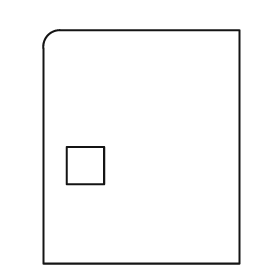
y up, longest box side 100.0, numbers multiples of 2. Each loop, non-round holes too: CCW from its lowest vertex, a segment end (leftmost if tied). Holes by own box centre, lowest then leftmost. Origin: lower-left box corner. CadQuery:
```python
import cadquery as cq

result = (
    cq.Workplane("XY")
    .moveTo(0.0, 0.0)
    .lineTo(84.0, 0.0)
    .lineTo(84.0, 100.0)
    .lineTo(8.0, 100.0)
    .threePointArc((2.0, 98.0), (0.0, 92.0))
    .close()
    .moveTo(10.0, 34.0)
    .lineTo(26.0, 34.0)
    .lineTo(26.0, 50.0)
    .lineTo(10.0, 50.0)
    .close()
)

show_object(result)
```